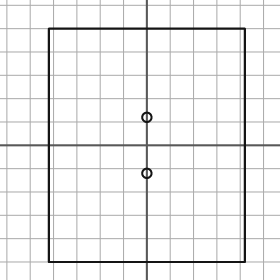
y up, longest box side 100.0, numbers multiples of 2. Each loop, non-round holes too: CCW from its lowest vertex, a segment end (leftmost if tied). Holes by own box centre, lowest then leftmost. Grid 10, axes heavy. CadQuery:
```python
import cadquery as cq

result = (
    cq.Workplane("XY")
    .moveTo(-42.0, -50.0)
    .lineTo(42.0, -50.0)
    .lineTo(42.0, 50.0)
    .lineTo(-42.0, 50.0)
    .close()
    .moveTo(0.0, -12.0)
    .circle(2.0)
    .moveTo(0.0, 12.0)
    .circle(2.0)
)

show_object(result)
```